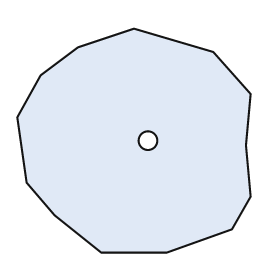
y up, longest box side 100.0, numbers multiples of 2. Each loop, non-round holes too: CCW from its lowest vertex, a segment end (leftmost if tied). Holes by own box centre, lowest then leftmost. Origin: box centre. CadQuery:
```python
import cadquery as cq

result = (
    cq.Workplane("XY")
    .moveTo(-14.0, -48.0)
    .lineTo(14.0, -48.0)
    .lineTo(42.0, -38.0)
    .lineTo(50.0, -24.0)
    .lineTo(48.0, -2.0)
    .lineTo(50.0, 20.0)
    .lineTo(34.0, 38.0)
    .lineTo(0.0, 48.0)
    .lineTo(-24.0, 40.0)
    .lineTo(-40.0, 28.0)
    .lineTo(-50.0, 10.0)
    .lineTo(-46.0, -18.0)
    .lineTo(-34.0, -32.0)
    .close()
    .moveTo(6.0, 0.0)
    .circle(4.0)
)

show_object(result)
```